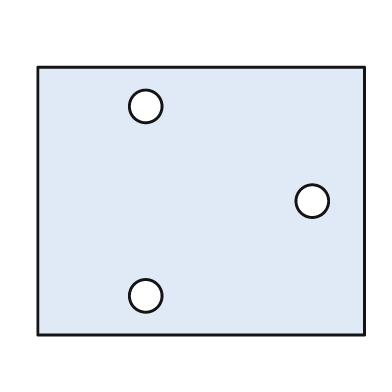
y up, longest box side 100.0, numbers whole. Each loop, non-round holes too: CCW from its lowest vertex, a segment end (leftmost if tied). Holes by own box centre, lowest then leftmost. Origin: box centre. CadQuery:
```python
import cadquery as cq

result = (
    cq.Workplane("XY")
    .moveTo(-50.0, -41.0)
    .lineTo(50.0, -41.0)
    .lineTo(50.0, 41.0)
    .lineTo(-50.0, 41.0)
    .close()
    .moveTo(-17.0, -29.0)
    .circle(5.0)
    .moveTo(34.0, 0.0)
    .circle(5.0)
    .moveTo(-17.0, 29.0)
    .circle(5.0)
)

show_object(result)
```